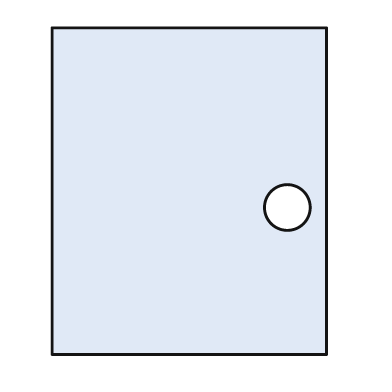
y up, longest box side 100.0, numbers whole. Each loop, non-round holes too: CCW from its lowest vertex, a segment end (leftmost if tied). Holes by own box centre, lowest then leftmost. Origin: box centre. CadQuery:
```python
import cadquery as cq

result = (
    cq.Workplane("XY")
    .moveTo(-42.0, -50.0)
    .lineTo(42.0, -50.0)
    .lineTo(42.0, 50.0)
    .lineTo(-42.0, 50.0)
    .close()
    .moveTo(30.0, -5.0)
    .circle(7.0)
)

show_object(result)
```